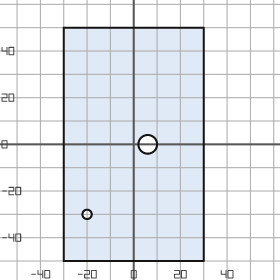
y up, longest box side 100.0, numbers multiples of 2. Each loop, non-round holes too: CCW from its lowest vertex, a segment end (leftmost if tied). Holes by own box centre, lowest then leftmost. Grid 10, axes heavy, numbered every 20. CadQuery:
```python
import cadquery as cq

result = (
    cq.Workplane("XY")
    .moveTo(-30.0, -50.0)
    .lineTo(30.0, -50.0)
    .lineTo(30.0, 50.0)
    .lineTo(-30.0, 50.0)
    .close()
    .moveTo(-20.0, -30.0)
    .circle(2.0)
    .moveTo(6.0, 0.0)
    .circle(4.0)
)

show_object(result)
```